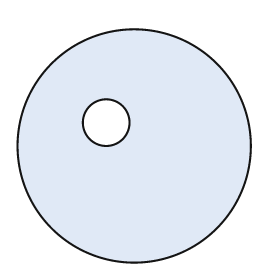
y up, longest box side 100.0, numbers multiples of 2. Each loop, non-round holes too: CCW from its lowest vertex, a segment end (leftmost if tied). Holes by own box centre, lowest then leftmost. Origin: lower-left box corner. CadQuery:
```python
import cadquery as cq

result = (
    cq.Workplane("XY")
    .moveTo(50.0, 50.0)
    .circle(50.0)
    .moveTo(38.0, 60.0)
    .circle(10.0)
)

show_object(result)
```